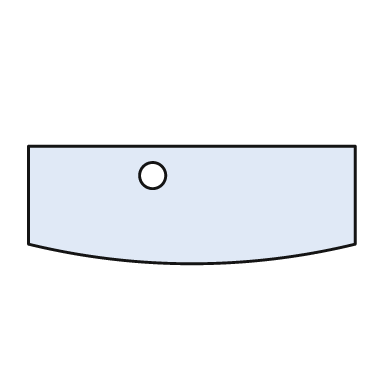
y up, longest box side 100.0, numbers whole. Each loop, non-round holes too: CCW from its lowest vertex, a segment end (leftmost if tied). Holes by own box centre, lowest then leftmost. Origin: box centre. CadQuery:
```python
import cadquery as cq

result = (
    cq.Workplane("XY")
    .moveTo(-50.0, -12.0)
    .threePointArc((0.0, -18.0), (50.0, -12.0))
    .lineTo(50.0, 18.0)
    .lineTo(-50.0, 18.0)
    .close()
    .moveTo(-12.0, 9.0)
    .circle(4.0)
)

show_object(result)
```